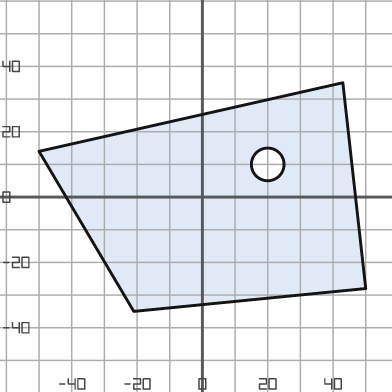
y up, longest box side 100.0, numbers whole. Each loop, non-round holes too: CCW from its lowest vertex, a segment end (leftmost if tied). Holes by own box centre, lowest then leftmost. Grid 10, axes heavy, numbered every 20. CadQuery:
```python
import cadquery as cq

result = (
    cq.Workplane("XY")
    .moveTo(-21.0, -35.0)
    .lineTo(50.0, -28.0)
    .lineTo(43.0, 35.0)
    .lineTo(-50.0, 14.0)
    .close()
    .moveTo(20.0, 10.0)
    .circle(5.0)
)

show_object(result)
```